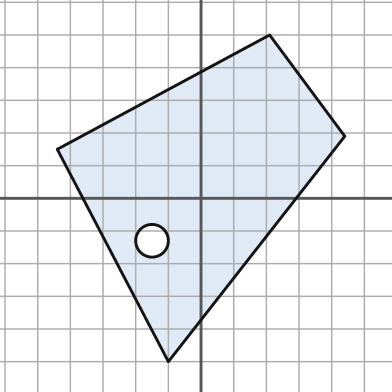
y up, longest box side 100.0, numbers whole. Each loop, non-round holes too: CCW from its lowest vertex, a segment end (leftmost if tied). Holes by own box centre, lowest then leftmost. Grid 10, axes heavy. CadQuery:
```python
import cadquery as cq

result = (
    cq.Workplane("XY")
    .moveTo(-10.0, -50.0)
    .lineTo(44.0, 19.0)
    .lineTo(21.0, 50.0)
    .lineTo(-44.0, 15.0)
    .close()
    .moveTo(-15.0, -13.0)
    .circle(5.0)
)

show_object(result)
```